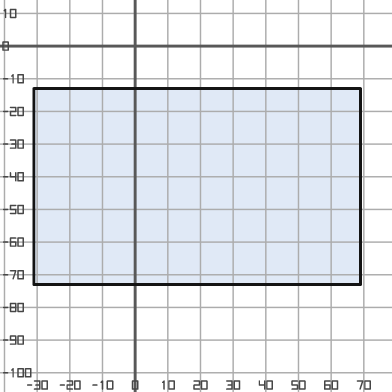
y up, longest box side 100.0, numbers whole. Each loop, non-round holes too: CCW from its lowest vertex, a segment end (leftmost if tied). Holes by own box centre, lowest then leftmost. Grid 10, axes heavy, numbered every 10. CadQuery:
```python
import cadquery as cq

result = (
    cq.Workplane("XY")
    .moveTo(-31.0, -73.0)
    .lineTo(69.0, -73.0)
    .lineTo(69.0, -13.0)
    .lineTo(-31.0, -13.0)
    .close()
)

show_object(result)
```